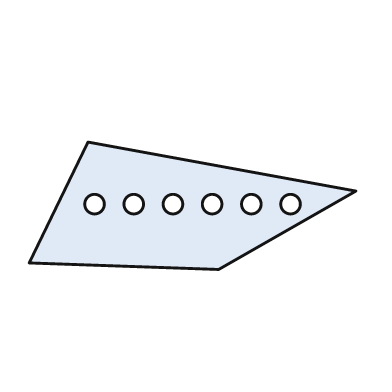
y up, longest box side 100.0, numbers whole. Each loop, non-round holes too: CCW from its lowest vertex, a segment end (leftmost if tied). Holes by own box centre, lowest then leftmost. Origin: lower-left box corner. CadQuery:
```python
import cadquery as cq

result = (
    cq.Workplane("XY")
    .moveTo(58.0, 0.0)
    .lineTo(100.0, 24.0)
    .lineTo(18.0, 39.0)
    .lineTo(0.0, 2.0)
    .close()
    .moveTo(20.0, 20.0)
    .circle(3.0)
    .moveTo(32.0, 20.0)
    .circle(3.0)
    .moveTo(44.0, 20.0)
    .circle(3.0)
    .moveTo(56.0, 20.0)
    .circle(3.0)
    .moveTo(68.0, 20.0)
    .circle(3.0)
    .moveTo(80.0, 20.0)
    .circle(3.0)
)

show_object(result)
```